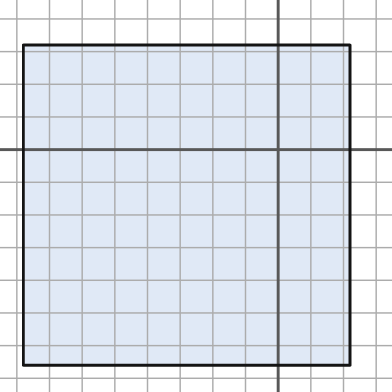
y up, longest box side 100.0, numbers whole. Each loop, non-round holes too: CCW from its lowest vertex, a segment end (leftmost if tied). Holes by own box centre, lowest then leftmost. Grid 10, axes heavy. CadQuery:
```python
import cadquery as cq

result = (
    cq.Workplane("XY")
    .moveTo(-78.0, -66.0)
    .lineTo(22.0, -66.0)
    .lineTo(22.0, 32.0)
    .lineTo(-78.0, 32.0)
    .close()
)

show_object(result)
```